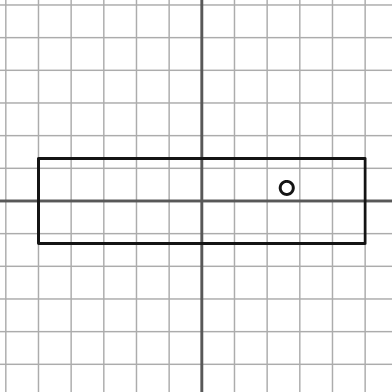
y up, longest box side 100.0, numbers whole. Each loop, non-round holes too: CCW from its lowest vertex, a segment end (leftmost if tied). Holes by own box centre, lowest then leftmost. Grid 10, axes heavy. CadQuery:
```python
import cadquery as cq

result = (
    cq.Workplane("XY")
    .moveTo(-50.0, -13.0)
    .lineTo(50.0, -13.0)
    .lineTo(50.0, 13.0)
    .lineTo(-50.0, 13.0)
    .close()
    .moveTo(26.0, 4.0)
    .circle(2.0)
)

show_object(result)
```